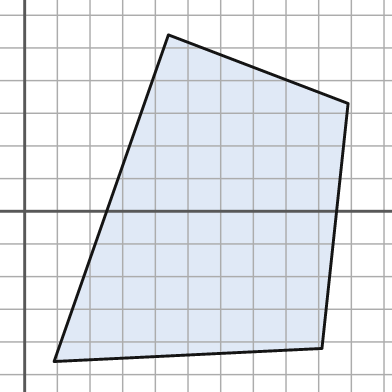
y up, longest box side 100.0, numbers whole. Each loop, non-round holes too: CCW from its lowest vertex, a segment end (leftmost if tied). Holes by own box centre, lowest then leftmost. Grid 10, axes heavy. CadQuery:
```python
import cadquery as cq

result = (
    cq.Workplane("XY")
    .moveTo(9.0, -46.0)
    .lineTo(91.0, -42.0)
    .lineTo(99.0, 33.0)
    .lineTo(44.0, 54.0)
    .close()
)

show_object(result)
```